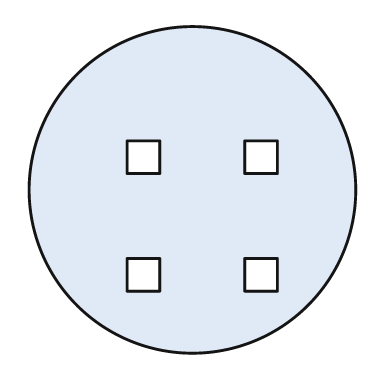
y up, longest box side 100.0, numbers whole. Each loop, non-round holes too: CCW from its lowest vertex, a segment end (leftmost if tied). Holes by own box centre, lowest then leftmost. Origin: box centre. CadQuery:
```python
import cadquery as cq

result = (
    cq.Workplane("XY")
    .moveTo(0.0, 0.0)
    .circle(50.0)
    .moveTo(-20.0, -31.0)
    .lineTo(-10.0, -31.0)
    .lineTo(-10.0, -21.0)
    .lineTo(-20.0, -21.0)
    .close()
    .moveTo(16.0, -31.0)
    .lineTo(26.0, -31.0)
    .lineTo(26.0, -21.0)
    .lineTo(16.0, -21.0)
    .close()
    .moveTo(-20.0, 5.0)
    .lineTo(-10.0, 5.0)
    .lineTo(-10.0, 15.0)
    .lineTo(-20.0, 15.0)
    .close()
    .moveTo(16.0, 5.0)
    .lineTo(26.0, 5.0)
    .lineTo(26.0, 15.0)
    .lineTo(16.0, 15.0)
    .close()
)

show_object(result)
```